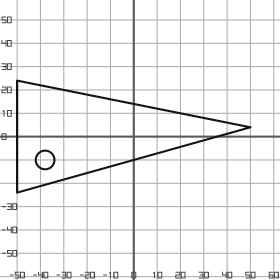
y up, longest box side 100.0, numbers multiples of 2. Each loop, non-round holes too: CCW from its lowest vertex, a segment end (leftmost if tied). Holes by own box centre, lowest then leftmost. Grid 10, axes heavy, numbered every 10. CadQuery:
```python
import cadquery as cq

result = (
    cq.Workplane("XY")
    .moveTo(-50.0, -24.0)
    .lineTo(50.0, 4.0)
    .lineTo(-50.0, 24.0)
    .close()
    .moveTo(-38.0, -10.0)
    .circle(4.0)
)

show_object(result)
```